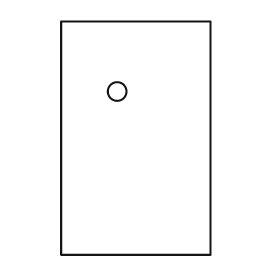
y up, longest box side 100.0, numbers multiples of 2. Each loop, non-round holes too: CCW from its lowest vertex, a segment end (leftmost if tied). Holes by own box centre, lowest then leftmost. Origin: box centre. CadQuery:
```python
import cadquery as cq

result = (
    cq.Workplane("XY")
    .moveTo(-32.0, -50.0)
    .lineTo(32.0, -50.0)
    .lineTo(32.0, 50.0)
    .lineTo(-32.0, 50.0)
    .close()
    .moveTo(-8.0, 20.0)
    .circle(4.0)
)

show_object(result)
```